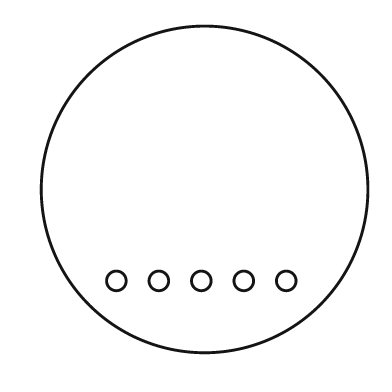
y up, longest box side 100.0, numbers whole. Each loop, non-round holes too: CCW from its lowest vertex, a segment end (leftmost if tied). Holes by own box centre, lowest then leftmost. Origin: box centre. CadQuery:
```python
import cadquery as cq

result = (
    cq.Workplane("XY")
    .moveTo(0.0, 0.0)
    .circle(50.0)
    .moveTo(-27.0, -28.0)
    .circle(3.0)
    .moveTo(-14.0, -28.0)
    .circle(3.0)
    .moveTo(-1.0, -28.0)
    .circle(3.0)
    .moveTo(12.0, -28.0)
    .circle(3.0)
    .moveTo(25.0, -28.0)
    .circle(3.0)
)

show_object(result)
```